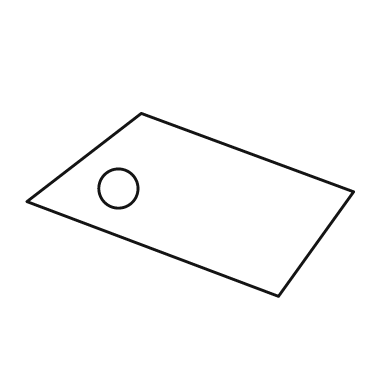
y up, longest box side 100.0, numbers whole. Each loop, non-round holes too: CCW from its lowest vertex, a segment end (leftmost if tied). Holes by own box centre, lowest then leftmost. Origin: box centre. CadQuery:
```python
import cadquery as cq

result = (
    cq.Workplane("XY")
    .moveTo(27.0, -28.0)
    .lineTo(50.0, 4.0)
    .lineTo(-15.0, 28.0)
    .lineTo(-50.0, 1.0)
    .close()
    .moveTo(-22.0, 5.0)
    .circle(6.0)
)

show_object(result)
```